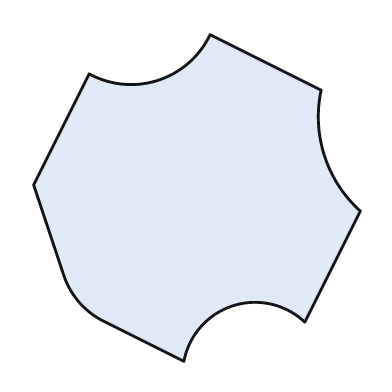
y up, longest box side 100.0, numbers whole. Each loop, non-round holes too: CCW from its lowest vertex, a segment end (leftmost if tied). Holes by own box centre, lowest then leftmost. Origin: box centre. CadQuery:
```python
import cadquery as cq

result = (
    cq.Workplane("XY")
    .moveTo(-4.0, -50.0)
    .threePointArc((11.0, -33.0), (33.0, -38.0))
    .lineTo(50.0, -4.0)
    .threePointArc((39.0, 13.0), (38.0, 33.0))
    .lineTo(4.0, 50.0)
    .threePointArc((-12.0, 36.0), (-33.0, 38.0))
    .lineTo(-50.0, 4.0)
    .lineTo(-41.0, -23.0)
    .threePointArc((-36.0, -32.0), (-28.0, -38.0))
    .close()
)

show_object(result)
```